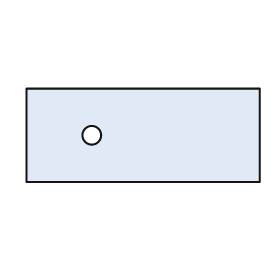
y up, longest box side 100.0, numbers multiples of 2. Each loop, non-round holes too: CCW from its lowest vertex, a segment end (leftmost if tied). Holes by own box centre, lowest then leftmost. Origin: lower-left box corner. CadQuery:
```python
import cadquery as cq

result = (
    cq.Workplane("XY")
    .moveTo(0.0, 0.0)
    .lineTo(100.0, 0.0)
    .lineTo(100.0, 40.0)
    .lineTo(0.0, 40.0)
    .close()
    .moveTo(28.0, 20.0)
    .circle(4.0)
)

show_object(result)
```